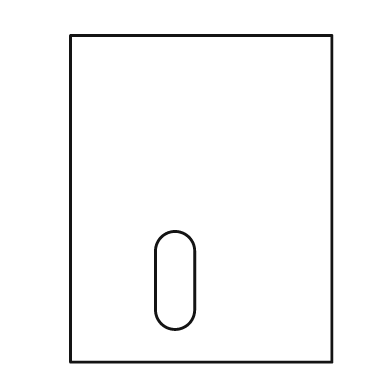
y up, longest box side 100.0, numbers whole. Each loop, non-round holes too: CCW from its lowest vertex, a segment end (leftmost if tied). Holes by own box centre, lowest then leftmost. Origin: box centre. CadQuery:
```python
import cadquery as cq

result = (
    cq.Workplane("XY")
    .moveTo(-40.0, -50.0)
    .lineTo(40.0, -50.0)
    .lineTo(40.0, 50.0)
    .lineTo(-40.0, 50.0)
    .close()
    .moveTo(-14.0, -34.0)
    .threePointArc((-8.0, -40.0), (-2.0, -34.0))
    .lineTo(-2.0, -16.0)
    .threePointArc((-8.0, -10.0), (-14.0, -16.0))
    .close()
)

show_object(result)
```